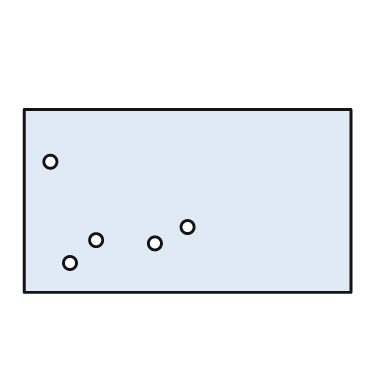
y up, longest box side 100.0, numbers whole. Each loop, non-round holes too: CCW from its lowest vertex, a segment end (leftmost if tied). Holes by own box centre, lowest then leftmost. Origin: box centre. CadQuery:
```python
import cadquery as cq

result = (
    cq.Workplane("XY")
    .moveTo(-50.0, -28.0)
    .lineTo(50.0, -28.0)
    .lineTo(50.0, 28.0)
    .lineTo(-50.0, 28.0)
    .close()
    .moveTo(-36.0, -19.0)
    .circle(2.0)
    .moveTo(-10.0, -13.0)
    .circle(2.0)
    .moveTo(-28.0, -12.0)
    .circle(2.0)
    .moveTo(0.0, -8.0)
    .circle(2.0)
    .moveTo(-42.0, 12.0)
    .circle(2.0)
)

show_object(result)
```